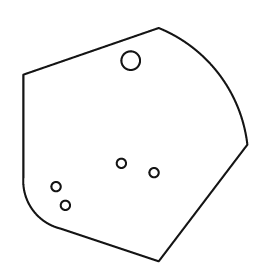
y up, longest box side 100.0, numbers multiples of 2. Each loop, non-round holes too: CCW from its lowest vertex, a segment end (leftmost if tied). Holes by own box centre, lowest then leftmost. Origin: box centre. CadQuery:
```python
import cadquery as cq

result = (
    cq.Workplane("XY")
    .moveTo(10.0, -50.0)
    .lineTo(48.0, 0.0)
    .threePointArc((36.0, 30.0), (10.0, 50.0))
    .lineTo(-48.0, 30.0)
    .lineTo(-48.0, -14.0)
    .threePointArc((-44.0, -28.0), (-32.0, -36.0))
    .close()
    .moveTo(-30.0, -26.0)
    .circle(2.0)
    .moveTo(-34.0, -18.0)
    .circle(2.0)
    .moveTo(8.0, -12.0)
    .circle(2.0)
    .moveTo(-6.0, -8.0)
    .circle(2.0)
    .moveTo(-2.0, 36.0)
    .circle(4.0)
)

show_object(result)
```